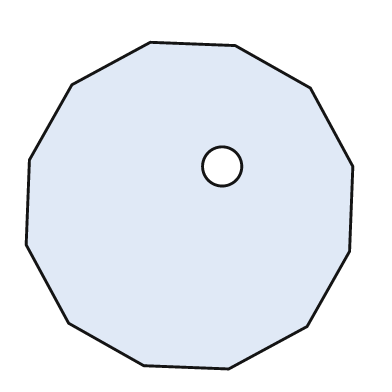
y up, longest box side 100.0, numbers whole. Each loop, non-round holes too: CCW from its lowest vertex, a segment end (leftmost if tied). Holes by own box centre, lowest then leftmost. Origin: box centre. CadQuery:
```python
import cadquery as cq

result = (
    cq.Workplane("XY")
    .moveTo(12.0, -50.0)
    .lineTo(36.0, -37.0)
    .lineTo(49.0, -14.0)
    .lineTo(50.0, 12.0)
    .lineTo(37.0, 36.0)
    .lineTo(14.0, 49.0)
    .lineTo(-12.0, 50.0)
    .lineTo(-36.0, 37.0)
    .lineTo(-49.0, 14.0)
    .lineTo(-50.0, -12.0)
    .lineTo(-37.0, -36.0)
    .lineTo(-14.0, -49.0)
    .close()
    .moveTo(10.0, 12.0)
    .circle(6.0)
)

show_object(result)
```